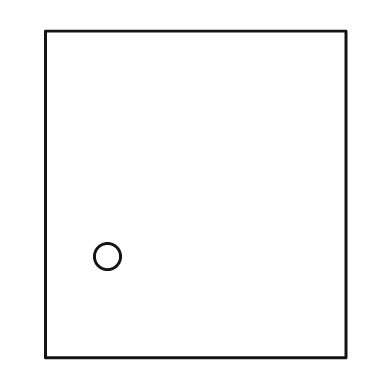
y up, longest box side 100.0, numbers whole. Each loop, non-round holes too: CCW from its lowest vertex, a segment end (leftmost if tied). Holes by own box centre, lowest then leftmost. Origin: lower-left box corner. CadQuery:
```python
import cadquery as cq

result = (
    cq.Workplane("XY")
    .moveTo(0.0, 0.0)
    .lineTo(92.0, 0.0)
    .lineTo(92.0, 100.0)
    .lineTo(0.0, 100.0)
    .close()
    .moveTo(19.0, 31.0)
    .circle(4.0)
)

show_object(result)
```